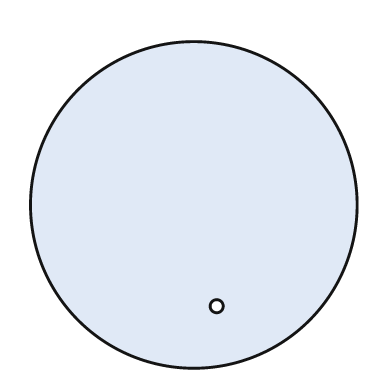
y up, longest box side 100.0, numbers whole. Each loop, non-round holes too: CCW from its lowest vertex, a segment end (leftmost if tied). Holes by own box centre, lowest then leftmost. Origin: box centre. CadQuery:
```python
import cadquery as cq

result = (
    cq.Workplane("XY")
    .moveTo(0.0, 0.0)
    .circle(50.0)
    .moveTo(7.0, -31.0)
    .circle(2.0)
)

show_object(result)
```